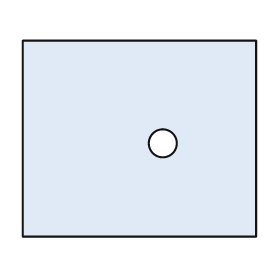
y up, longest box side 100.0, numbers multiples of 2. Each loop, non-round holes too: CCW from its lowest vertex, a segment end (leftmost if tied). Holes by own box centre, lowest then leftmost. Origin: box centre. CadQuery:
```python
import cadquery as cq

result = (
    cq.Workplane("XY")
    .moveTo(-50.0, -42.0)
    .lineTo(50.0, -42.0)
    .lineTo(50.0, 42.0)
    .lineTo(-50.0, 42.0)
    .close()
    .moveTo(10.0, -2.0)
    .circle(6.0)
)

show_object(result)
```